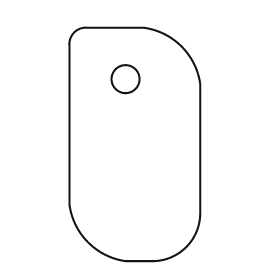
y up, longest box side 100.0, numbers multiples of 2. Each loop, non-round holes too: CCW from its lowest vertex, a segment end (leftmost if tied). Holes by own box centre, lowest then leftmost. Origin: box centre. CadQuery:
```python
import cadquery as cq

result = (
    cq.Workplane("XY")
    .moveTo(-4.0, -50.0)
    .lineTo(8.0, -50.0)
    .threePointArc((22.0, -44.0), (28.0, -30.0))
    .lineTo(28.0, 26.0)
    .threePointArc((20.0, 42.0), (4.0, 50.0))
    .lineTo(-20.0, 50.0)
    .threePointArc((-26.0, 48.0), (-28.0, 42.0))
    .lineTo(-28.0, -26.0)
    .threePointArc((-20.0, -42.0), (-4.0, -50.0))
    .close()
    .moveTo(-4.0, 28.0)
    .circle(6.0)
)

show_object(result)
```